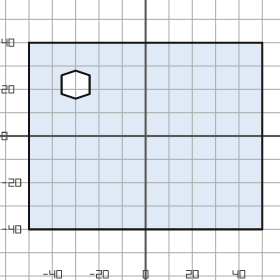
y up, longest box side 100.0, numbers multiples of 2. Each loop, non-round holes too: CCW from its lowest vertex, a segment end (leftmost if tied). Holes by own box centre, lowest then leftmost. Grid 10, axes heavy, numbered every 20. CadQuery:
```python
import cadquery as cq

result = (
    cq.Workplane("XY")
    .moveTo(-50.0, -40.0)
    .lineTo(50.0, -40.0)
    .lineTo(50.0, 40.0)
    .lineTo(-50.0, 40.0)
    .close()
    .moveTo(-30.0, 16.0)
    .lineTo(-24.0, 18.0)
    .lineTo(-24.0, 26.0)
    .lineTo(-30.0, 28.0)
    .lineTo(-36.0, 26.0)
    .lineTo(-36.0, 18.0)
    .close()
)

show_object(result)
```